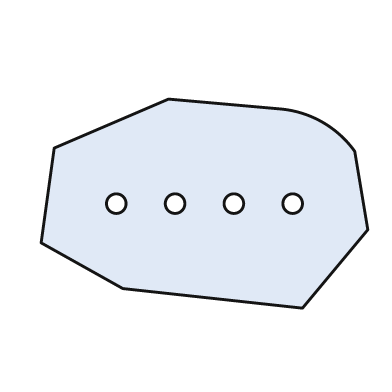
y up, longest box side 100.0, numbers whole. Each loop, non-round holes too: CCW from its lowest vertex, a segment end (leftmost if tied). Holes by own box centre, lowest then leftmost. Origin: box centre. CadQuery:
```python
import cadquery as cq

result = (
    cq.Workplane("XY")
    .moveTo(30.0, -32.0)
    .lineTo(50.0, -8.0)
    .lineTo(46.0, 16.0)
    .threePointArc((36.0, 25.0), (23.0, 29.0))
    .lineTo(-11.0, 32.0)
    .lineTo(-46.0, 17.0)
    .lineTo(-50.0, -12.0)
    .lineTo(-25.0, -26.0)
    .close()
    .moveTo(-27.0, 0.0)
    .circle(3.0)
    .moveTo(-9.0, 0.0)
    .circle(3.0)
    .moveTo(9.0, 0.0)
    .circle(3.0)
    .moveTo(27.0, 0.0)
    .circle(3.0)
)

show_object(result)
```